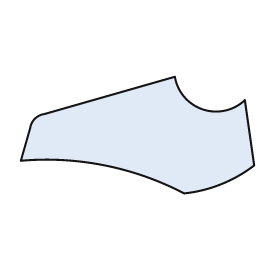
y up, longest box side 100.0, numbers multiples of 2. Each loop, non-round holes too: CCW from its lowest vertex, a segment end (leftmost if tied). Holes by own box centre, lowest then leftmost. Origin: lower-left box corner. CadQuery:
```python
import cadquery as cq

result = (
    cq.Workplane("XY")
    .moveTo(70.0, 0.0)
    .threePointArc((86.0, 4.0), (100.0, 12.0))
    .lineTo(96.0, 40.0)
    .threePointArc((78.0, 36.0), (66.0, 50.0))
    .lineTo(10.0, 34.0)
    .threePointArc((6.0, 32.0), (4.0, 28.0))
    .lineTo(0.0, 14.0)
    .threePointArc((36.0, 12.0), (70.0, 0.0))
    .close()
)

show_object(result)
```